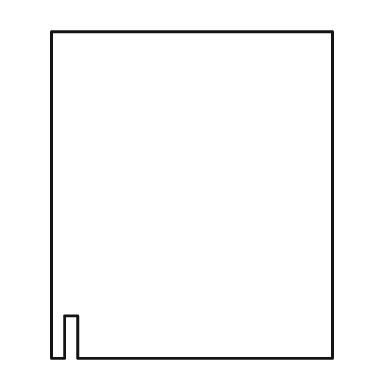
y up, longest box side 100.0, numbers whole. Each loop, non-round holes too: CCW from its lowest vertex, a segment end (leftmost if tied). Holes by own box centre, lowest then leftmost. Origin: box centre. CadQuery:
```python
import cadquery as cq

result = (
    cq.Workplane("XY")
    .moveTo(-43.0, -50.0)
    .lineTo(-39.0, -50.0)
    .lineTo(-39.0, -37.0)
    .lineTo(-35.0, -37.0)
    .lineTo(-35.0, -50.0)
    .lineTo(43.0, -50.0)
    .lineTo(43.0, 50.0)
    .lineTo(-43.0, 50.0)
    .close()
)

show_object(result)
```